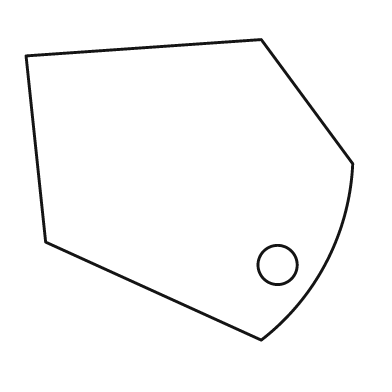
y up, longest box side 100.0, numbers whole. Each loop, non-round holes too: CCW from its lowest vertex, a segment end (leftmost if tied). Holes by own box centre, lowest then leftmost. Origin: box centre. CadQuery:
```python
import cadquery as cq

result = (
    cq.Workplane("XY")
    .moveTo(22.0, -46.0)
    .threePointArc((42.0, -22.0), (50.0, 8.0))
    .lineTo(22.0, 46.0)
    .lineTo(-50.0, 41.0)
    .lineTo(-44.0, -16.0)
    .close()
    .moveTo(27.0, -23.0)
    .circle(6.0)
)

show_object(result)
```